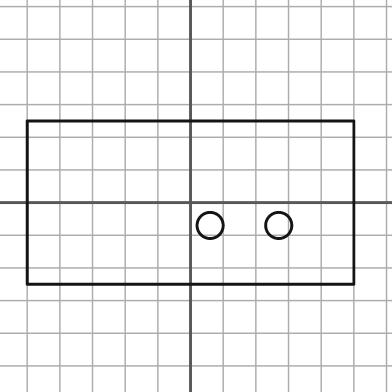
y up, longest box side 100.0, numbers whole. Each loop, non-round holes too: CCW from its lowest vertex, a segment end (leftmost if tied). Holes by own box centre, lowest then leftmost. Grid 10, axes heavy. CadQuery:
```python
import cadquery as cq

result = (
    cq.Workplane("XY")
    .moveTo(-50.0, -25.0)
    .lineTo(50.0, -25.0)
    .lineTo(50.0, 25.0)
    .lineTo(-50.0, 25.0)
    .close()
    .moveTo(6.0, -7.0)
    .circle(4.0)
    .moveTo(27.0, -7.0)
    .circle(4.0)
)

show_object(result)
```